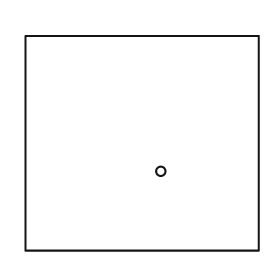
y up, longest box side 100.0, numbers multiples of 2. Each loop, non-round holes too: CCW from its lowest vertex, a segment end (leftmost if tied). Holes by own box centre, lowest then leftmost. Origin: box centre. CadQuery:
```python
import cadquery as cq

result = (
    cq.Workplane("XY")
    .moveTo(-50.0, -46.0)
    .lineTo(50.0, -46.0)
    .lineTo(50.0, 46.0)
    .lineTo(-50.0, 46.0)
    .close()
    .moveTo(8.0, -12.0)
    .circle(2.0)
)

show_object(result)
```